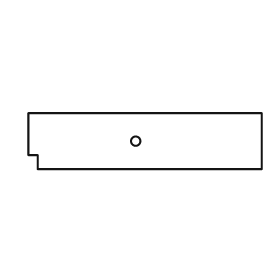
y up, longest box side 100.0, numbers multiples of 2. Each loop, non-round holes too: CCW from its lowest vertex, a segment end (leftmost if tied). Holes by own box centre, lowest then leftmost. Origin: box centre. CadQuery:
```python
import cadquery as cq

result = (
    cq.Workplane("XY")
    .moveTo(-46.0, -12.0)
    .lineTo(50.0, -12.0)
    .lineTo(50.0, 12.0)
    .lineTo(-50.0, 12.0)
    .lineTo(-50.0, -6.0)
    .lineTo(-46.0, -6.0)
    .close()
    .moveTo(-4.0, 0.0)
    .circle(2.0)
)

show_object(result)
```